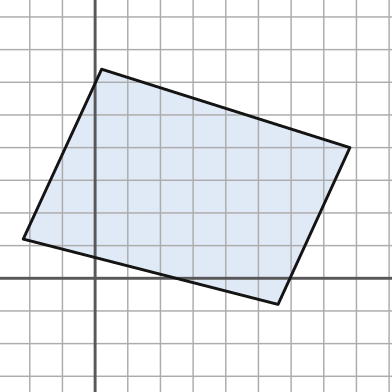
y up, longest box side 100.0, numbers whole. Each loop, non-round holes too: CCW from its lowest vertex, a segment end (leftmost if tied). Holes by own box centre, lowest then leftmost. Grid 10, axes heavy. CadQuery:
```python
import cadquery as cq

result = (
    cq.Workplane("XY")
    .moveTo(56.0, -8.0)
    .lineTo(78.0, 40.0)
    .lineTo(2.0, 64.0)
    .lineTo(-22.0, 12.0)
    .close()
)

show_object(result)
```